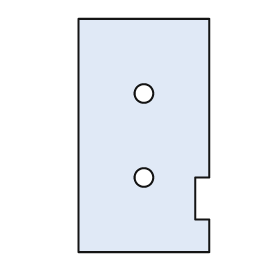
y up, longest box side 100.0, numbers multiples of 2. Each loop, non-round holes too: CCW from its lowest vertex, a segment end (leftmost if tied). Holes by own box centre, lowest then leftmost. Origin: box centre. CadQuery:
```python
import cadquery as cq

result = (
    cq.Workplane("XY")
    .moveTo(-28.0, -50.0)
    .lineTo(28.0, -50.0)
    .lineTo(28.0, -36.0)
    .lineTo(22.0, -36.0)
    .lineTo(22.0, -18.0)
    .lineTo(28.0, -18.0)
    .lineTo(28.0, 50.0)
    .lineTo(-28.0, 50.0)
    .close()
    .moveTo(0.0, -18.0)
    .circle(4.0)
    .moveTo(0.0, 18.0)
    .circle(4.0)
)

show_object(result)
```